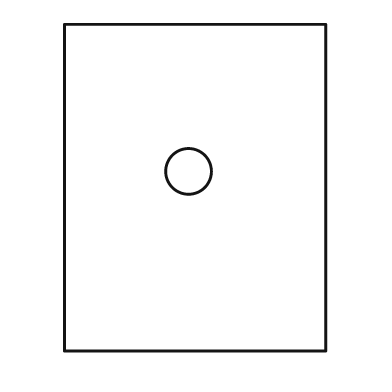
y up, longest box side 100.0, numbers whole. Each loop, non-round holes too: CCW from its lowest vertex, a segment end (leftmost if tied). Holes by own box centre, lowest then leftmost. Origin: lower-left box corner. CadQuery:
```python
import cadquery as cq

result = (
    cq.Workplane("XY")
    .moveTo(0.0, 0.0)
    .lineTo(80.0, 0.0)
    .lineTo(80.0, 100.0)
    .lineTo(0.0, 100.0)
    .close()
    .moveTo(38.0, 55.0)
    .circle(7.0)
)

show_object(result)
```